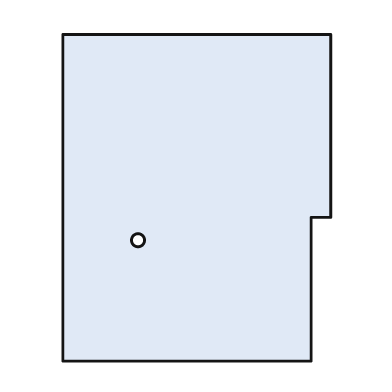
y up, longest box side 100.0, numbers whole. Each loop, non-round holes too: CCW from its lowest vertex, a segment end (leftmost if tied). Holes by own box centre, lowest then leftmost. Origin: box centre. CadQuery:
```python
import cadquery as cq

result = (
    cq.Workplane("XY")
    .moveTo(-41.0, -50.0)
    .lineTo(35.0, -50.0)
    .lineTo(35.0, -6.0)
    .lineTo(41.0, -6.0)
    .lineTo(41.0, 50.0)
    .lineTo(-41.0, 50.0)
    .close()
    .moveTo(-18.0, -13.0)
    .circle(2.0)
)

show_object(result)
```